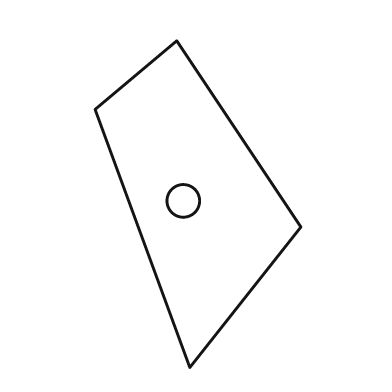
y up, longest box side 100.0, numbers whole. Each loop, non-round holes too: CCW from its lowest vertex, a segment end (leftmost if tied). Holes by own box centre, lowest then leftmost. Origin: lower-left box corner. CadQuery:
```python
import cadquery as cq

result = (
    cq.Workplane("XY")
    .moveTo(29.0, 0.0)
    .lineTo(63.0, 43.0)
    .lineTo(25.0, 100.0)
    .lineTo(0.0, 79.0)
    .close()
    .moveTo(27.0, 51.0)
    .circle(5.0)
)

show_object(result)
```